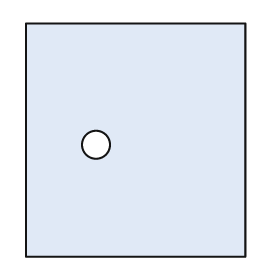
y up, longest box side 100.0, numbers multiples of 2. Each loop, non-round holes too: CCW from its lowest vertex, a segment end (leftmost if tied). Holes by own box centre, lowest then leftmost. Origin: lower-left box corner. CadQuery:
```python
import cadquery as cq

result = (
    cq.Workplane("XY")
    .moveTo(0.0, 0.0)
    .lineTo(94.0, 0.0)
    .lineTo(94.0, 100.0)
    .lineTo(0.0, 100.0)
    .close()
    .moveTo(30.0, 48.0)
    .circle(6.0)
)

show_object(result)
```